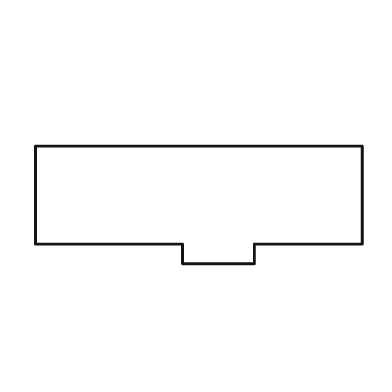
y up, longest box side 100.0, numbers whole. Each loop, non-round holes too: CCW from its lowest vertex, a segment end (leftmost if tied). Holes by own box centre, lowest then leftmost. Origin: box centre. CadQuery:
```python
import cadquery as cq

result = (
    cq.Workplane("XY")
    .moveTo(-5.0, -18.0)
    .lineTo(17.0, -18.0)
    .lineTo(17.0, -12.0)
    .lineTo(50.0, -12.0)
    .lineTo(50.0, 18.0)
    .lineTo(-50.0, 18.0)
    .lineTo(-50.0, -12.0)
    .lineTo(-5.0, -12.0)
    .close()
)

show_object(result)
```